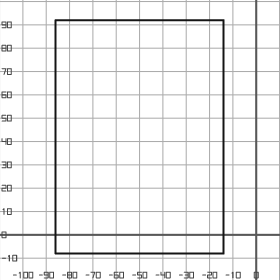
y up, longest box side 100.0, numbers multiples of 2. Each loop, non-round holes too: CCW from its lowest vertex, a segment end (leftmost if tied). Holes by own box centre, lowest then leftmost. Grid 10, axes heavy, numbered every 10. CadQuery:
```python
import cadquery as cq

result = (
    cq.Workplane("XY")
    .moveTo(-86.0, -8.0)
    .lineTo(-14.0, -8.0)
    .lineTo(-14.0, 92.0)
    .lineTo(-86.0, 92.0)
    .close()
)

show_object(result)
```